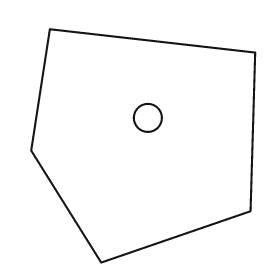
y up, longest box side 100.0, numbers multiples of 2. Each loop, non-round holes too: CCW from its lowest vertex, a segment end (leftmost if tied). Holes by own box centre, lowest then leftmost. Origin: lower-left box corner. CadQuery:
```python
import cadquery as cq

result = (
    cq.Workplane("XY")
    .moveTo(30.0, 0.0)
    .lineTo(94.0, 22.0)
    .lineTo(96.0, 90.0)
    .lineTo(8.0, 100.0)
    .lineTo(0.0, 48.0)
    .close()
    .moveTo(50.0, 62.0)
    .circle(6.0)
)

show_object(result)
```